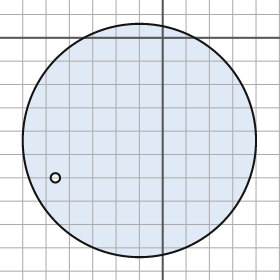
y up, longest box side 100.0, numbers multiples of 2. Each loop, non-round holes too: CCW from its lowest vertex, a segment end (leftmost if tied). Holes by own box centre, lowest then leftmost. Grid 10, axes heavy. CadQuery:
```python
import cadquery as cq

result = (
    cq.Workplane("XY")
    .moveTo(-10.0, -44.0)
    .circle(50.0)
    .moveTo(-46.0, -60.0)
    .circle(2.0)
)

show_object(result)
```